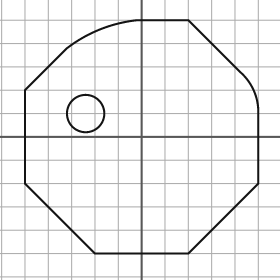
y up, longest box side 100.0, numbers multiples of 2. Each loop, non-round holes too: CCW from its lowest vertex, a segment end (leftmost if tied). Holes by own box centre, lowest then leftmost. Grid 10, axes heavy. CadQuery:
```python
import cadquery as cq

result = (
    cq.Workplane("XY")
    .moveTo(-20.0, -50.0)
    .lineTo(20.0, -50.0)
    .lineTo(50.0, -20.0)
    .lineTo(50.0, 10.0)
    .threePointArc((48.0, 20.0), (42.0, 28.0))
    .lineTo(20.0, 50.0)
    .lineTo(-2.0, 50.0)
    .threePointArc((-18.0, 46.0), (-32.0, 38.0))
    .lineTo(-50.0, 20.0)
    .lineTo(-50.0, -20.0)
    .close()
    .moveTo(-24.0, 10.0)
    .circle(8.0)
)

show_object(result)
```